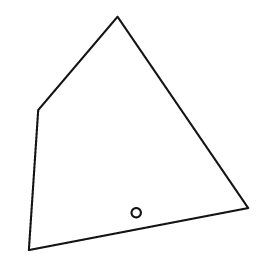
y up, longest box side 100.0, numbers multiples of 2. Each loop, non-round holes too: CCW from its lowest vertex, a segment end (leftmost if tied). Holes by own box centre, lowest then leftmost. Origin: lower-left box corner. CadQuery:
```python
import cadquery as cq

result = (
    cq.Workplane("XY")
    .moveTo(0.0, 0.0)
    .lineTo(94.0, 18.0)
    .lineTo(38.0, 100.0)
    .lineTo(4.0, 60.0)
    .close()
    .moveTo(46.0, 16.0)
    .circle(2.0)
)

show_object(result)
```